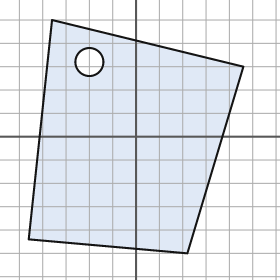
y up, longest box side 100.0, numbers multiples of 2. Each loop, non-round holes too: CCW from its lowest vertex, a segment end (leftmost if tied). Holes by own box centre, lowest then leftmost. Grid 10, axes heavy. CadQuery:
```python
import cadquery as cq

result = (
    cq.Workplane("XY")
    .moveTo(22.0, -50.0)
    .lineTo(46.0, 30.0)
    .lineTo(-36.0, 50.0)
    .lineTo(-46.0, -44.0)
    .close()
    .moveTo(-20.0, 32.0)
    .circle(6.0)
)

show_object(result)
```